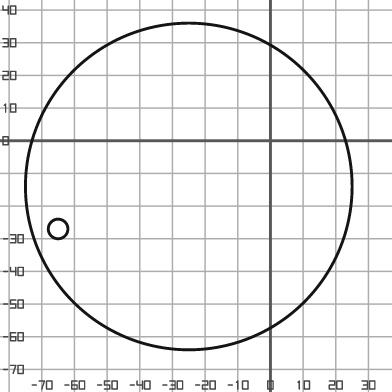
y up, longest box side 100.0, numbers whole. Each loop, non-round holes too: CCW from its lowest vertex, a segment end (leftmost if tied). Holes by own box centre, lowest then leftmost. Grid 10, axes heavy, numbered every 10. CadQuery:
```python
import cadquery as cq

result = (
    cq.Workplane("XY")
    .moveTo(-25.0, -14.0)
    .circle(50.0)
    .moveTo(-65.0, -27.0)
    .circle(3.0)
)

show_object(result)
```